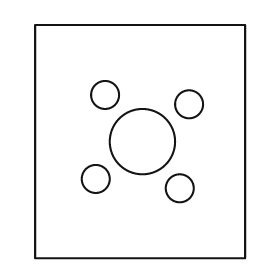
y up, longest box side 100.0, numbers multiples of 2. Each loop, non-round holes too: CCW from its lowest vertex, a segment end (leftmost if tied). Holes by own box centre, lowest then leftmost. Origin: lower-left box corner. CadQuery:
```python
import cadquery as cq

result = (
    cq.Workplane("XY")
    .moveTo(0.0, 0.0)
    .lineTo(90.0, 0.0)
    .lineTo(90.0, 100.0)
    .lineTo(0.0, 100.0)
    .close()
    .moveTo(62.0, 30.0)
    .circle(6.0)
    .moveTo(26.0, 34.0)
    .circle(6.0)
    .moveTo(46.0, 50.0)
    .circle(14.0)
    .moveTo(66.0, 66.0)
    .circle(6.0)
    .moveTo(30.0, 70.0)
    .circle(6.0)
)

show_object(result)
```